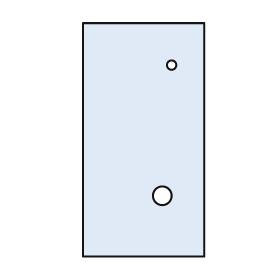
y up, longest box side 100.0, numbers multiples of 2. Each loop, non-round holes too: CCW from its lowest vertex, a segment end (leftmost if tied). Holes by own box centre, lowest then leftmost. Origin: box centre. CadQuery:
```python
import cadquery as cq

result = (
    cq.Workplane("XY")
    .moveTo(-26.0, -50.0)
    .lineTo(26.0, -50.0)
    .lineTo(26.0, 50.0)
    .lineTo(-26.0, 50.0)
    .close()
    .moveTo(8.0, -24.0)
    .circle(4.0)
    .moveTo(12.0, 32.0)
    .circle(2.0)
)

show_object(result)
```